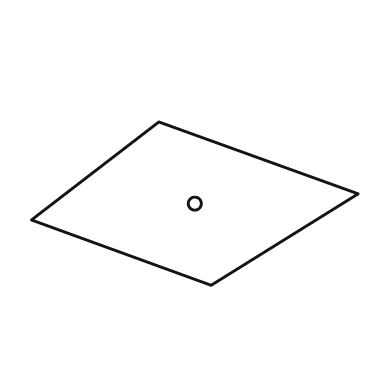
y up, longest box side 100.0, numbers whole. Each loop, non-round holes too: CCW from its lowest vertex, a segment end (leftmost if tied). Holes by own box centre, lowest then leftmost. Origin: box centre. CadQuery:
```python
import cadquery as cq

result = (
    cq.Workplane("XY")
    .moveTo(5.0, -25.0)
    .lineTo(50.0, 3.0)
    .lineTo(-11.0, 25.0)
    .lineTo(-50.0, -5.0)
    .close()
    .moveTo(0.0, 0.0)
    .circle(2.0)
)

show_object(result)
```